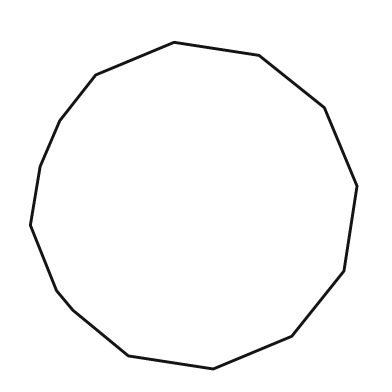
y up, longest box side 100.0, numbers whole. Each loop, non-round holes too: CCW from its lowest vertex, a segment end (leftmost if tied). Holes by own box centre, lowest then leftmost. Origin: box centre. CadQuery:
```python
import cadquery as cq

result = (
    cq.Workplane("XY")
    .moveTo(6.0, -50.0)
    .lineTo(30.0, -40.0)
    .lineTo(46.0, -20.0)
    .lineTo(50.0, 6.0)
    .lineTo(40.0, 30.0)
    .lineTo(20.0, 46.0)
    .lineTo(-6.0, 50.0)
    .lineTo(-30.0, 40.0)
    .lineTo(-41.0, 26.0)
    .lineTo(-47.0, 12.0)
    .lineTo(-50.0, -6.0)
    .lineTo(-42.0, -26.0)
    .lineTo(-37.0, -32.0)
    .lineTo(-20.0, -46.0)
    .close()
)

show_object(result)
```